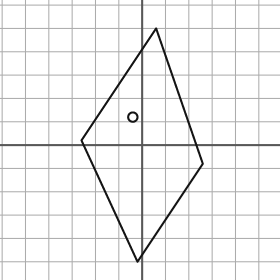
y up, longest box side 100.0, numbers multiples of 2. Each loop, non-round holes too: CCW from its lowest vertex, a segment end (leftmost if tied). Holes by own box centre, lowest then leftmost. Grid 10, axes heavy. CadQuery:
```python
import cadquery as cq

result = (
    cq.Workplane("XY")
    .moveTo(-2.0, -50.0)
    .lineTo(26.0, -8.0)
    .lineTo(6.0, 50.0)
    .lineTo(-26.0, 2.0)
    .close()
    .moveTo(-4.0, 12.0)
    .circle(2.0)
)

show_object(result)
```